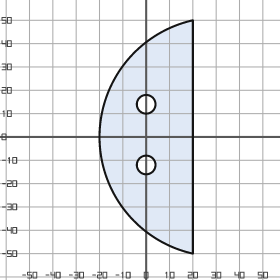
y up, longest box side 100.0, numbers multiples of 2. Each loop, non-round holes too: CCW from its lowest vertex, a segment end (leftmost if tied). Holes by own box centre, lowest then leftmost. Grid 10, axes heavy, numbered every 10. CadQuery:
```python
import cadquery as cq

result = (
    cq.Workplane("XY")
    .moveTo(20.0, -50.0)
    .lineTo(20.0, 50.0)
    .threePointArc((-20.0, 0.0), (20.0, -50.0))
    .close()
    .moveTo(0.0, -12.0)
    .circle(4.0)
    .moveTo(0.0, 14.0)
    .circle(4.0)
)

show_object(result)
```